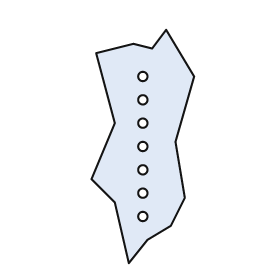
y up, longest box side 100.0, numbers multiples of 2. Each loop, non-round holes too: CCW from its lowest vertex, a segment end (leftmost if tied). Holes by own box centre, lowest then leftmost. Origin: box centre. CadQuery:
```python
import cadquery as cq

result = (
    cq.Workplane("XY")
    .moveTo(-6.0, -50.0)
    .lineTo(2.0, -40.0)
    .lineTo(12.0, -34.0)
    .lineTo(18.0, -22.0)
    .lineTo(14.0, 2.0)
    .lineTo(22.0, 30.0)
    .lineTo(10.0, 50.0)
    .lineTo(4.0, 42.0)
    .lineTo(-4.0, 44.0)
    .lineTo(-20.0, 40.0)
    .lineTo(-12.0, 10.0)
    .lineTo(-22.0, -14.0)
    .lineTo(-12.0, -24.0)
    .close()
    .moveTo(0.0, -30.0)
    .circle(2.0)
    .moveTo(0.0, -20.0)
    .circle(2.0)
    .moveTo(0.0, -10.0)
    .circle(2.0)
    .moveTo(0.0, 0.0)
    .circle(2.0)
    .moveTo(0.0, 10.0)
    .circle(2.0)
    .moveTo(0.0, 20.0)
    .circle(2.0)
    .moveTo(0.0, 30.0)
    .circle(2.0)
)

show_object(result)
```